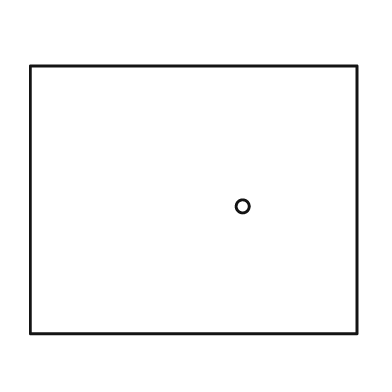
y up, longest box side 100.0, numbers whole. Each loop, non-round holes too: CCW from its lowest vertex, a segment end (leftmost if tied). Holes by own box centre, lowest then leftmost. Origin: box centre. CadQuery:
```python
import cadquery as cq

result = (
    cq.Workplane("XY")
    .moveTo(-50.0, -41.0)
    .lineTo(50.0, -41.0)
    .lineTo(50.0, 41.0)
    .lineTo(-50.0, 41.0)
    .close()
    .moveTo(15.0, -2.0)
    .circle(2.0)
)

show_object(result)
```